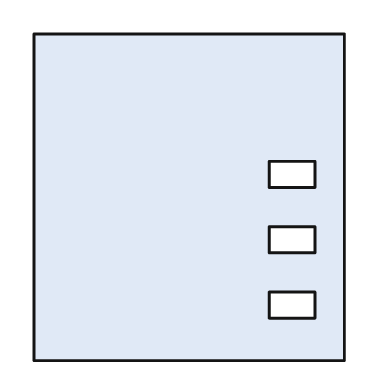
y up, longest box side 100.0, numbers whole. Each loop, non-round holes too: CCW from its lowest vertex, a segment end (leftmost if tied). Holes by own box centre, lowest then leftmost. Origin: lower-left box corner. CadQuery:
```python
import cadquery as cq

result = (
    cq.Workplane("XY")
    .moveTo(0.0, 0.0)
    .lineTo(95.0, 0.0)
    .lineTo(95.0, 100.0)
    .lineTo(0.0, 100.0)
    .close()
    .moveTo(72.0, 13.0)
    .lineTo(86.0, 13.0)
    .lineTo(86.0, 21.0)
    .lineTo(72.0, 21.0)
    .close()
    .moveTo(72.0, 33.0)
    .lineTo(86.0, 33.0)
    .lineTo(86.0, 41.0)
    .lineTo(72.0, 41.0)
    .close()
    .moveTo(72.0, 53.0)
    .lineTo(86.0, 53.0)
    .lineTo(86.0, 61.0)
    .lineTo(72.0, 61.0)
    .close()
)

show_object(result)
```